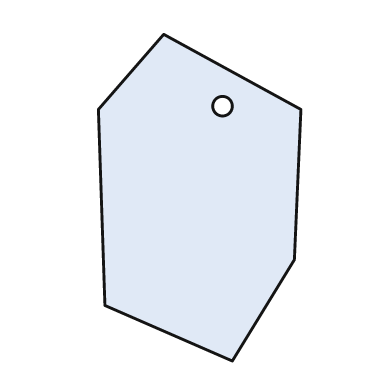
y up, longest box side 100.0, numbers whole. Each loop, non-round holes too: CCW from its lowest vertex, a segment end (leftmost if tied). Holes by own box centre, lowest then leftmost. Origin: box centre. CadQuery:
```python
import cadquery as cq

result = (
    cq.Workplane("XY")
    .moveTo(10.0, -50.0)
    .lineTo(29.0, -19.0)
    .lineTo(31.0, 27.0)
    .lineTo(-11.0, 50.0)
    .lineTo(-31.0, 27.0)
    .lineTo(-29.0, -33.0)
    .close()
    .moveTo(7.0, 28.0)
    .circle(3.0)
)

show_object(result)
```